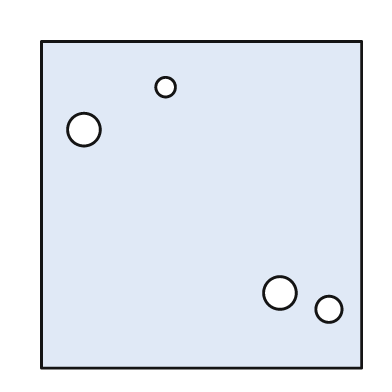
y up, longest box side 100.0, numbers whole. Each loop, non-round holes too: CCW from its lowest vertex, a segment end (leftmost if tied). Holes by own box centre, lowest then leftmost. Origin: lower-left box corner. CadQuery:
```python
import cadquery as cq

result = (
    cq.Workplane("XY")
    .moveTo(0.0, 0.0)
    .lineTo(98.0, 0.0)
    .lineTo(98.0, 100.0)
    .lineTo(0.0, 100.0)
    .close()
    .moveTo(88.0, 18.0)
    .circle(4.0)
    .moveTo(73.0, 23.0)
    .circle(5.0)
    .moveTo(13.0, 73.0)
    .circle(5.0)
    .moveTo(38.0, 86.0)
    .circle(3.0)
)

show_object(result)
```